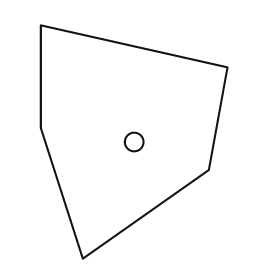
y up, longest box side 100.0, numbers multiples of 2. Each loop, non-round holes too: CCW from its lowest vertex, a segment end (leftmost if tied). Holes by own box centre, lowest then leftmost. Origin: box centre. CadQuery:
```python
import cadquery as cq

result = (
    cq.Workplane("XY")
    .moveTo(-22.0, -50.0)
    .lineTo(32.0, -12.0)
    .lineTo(40.0, 32.0)
    .lineTo(-40.0, 50.0)
    .lineTo(-40.0, 6.0)
    .close()
    .moveTo(0.0, 0.0)
    .circle(4.0)
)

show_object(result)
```